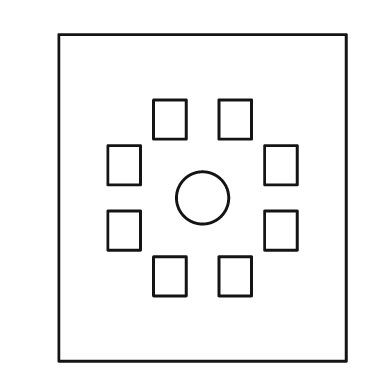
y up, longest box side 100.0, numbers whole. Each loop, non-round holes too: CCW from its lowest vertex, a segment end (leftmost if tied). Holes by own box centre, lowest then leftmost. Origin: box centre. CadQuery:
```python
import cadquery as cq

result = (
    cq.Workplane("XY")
    .moveTo(-44.0, -50.0)
    .lineTo(44.0, -50.0)
    .lineTo(44.0, 50.0)
    .lineTo(-44.0, 50.0)
    .close()
    .moveTo(-15.0, -30.0)
    .lineTo(-5.0, -30.0)
    .lineTo(-5.0, -18.0)
    .lineTo(-15.0, -18.0)
    .close()
    .moveTo(5.0, -30.0)
    .lineTo(15.0, -30.0)
    .lineTo(15.0, -18.0)
    .lineTo(5.0, -18.0)
    .close()
    .moveTo(-29.0, -16.0)
    .lineTo(-19.0, -16.0)
    .lineTo(-19.0, -4.0)
    .lineTo(-29.0, -4.0)
    .close()
    .moveTo(19.0, -16.0)
    .lineTo(29.0, -16.0)
    .lineTo(29.0, -4.0)
    .lineTo(19.0, -4.0)
    .close()
    .moveTo(0.0, 0.0)
    .circle(8.0)
    .moveTo(-29.0, 4.0)
    .lineTo(-19.0, 4.0)
    .lineTo(-19.0, 16.0)
    .lineTo(-29.0, 16.0)
    .close()
    .moveTo(19.0, 4.0)
    .lineTo(29.0, 4.0)
    .lineTo(29.0, 16.0)
    .lineTo(19.0, 16.0)
    .close()
    .moveTo(-15.0, 18.0)
    .lineTo(-5.0, 18.0)
    .lineTo(-5.0, 30.0)
    .lineTo(-15.0, 30.0)
    .close()
    .moveTo(5.0, 18.0)
    .lineTo(15.0, 18.0)
    .lineTo(15.0, 30.0)
    .lineTo(5.0, 30.0)
    .close()
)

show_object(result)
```